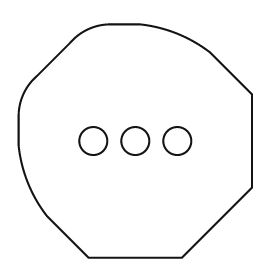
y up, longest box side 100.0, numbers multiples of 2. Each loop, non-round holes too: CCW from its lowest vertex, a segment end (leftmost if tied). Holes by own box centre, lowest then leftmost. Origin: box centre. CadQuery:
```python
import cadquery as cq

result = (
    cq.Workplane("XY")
    .moveTo(-20.0, -50.0)
    .lineTo(20.0, -50.0)
    .lineTo(50.0, -20.0)
    .lineTo(50.0, 20.0)
    .lineTo(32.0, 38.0)
    .threePointArc((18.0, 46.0), (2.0, 50.0))
    .lineTo(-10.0, 50.0)
    .threePointArc((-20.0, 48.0), (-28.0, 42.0))
    .lineTo(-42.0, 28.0)
    .threePointArc((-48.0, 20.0), (-50.0, 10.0))
    .lineTo(-50.0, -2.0)
    .threePointArc((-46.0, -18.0), (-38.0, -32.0))
    .close()
    .moveTo(-18.0, 0.0)
    .circle(6.0)
    .moveTo(0.0, 0.0)
    .circle(6.0)
    .moveTo(18.0, 0.0)
    .circle(6.0)
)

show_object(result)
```